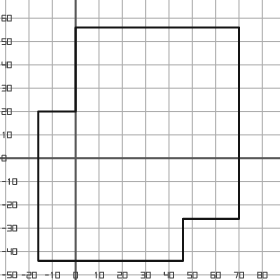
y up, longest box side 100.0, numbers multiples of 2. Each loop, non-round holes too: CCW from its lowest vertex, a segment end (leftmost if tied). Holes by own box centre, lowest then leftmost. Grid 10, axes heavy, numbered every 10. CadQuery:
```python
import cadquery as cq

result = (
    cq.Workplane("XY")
    .moveTo(-16.0, -44.0)
    .lineTo(46.0, -44.0)
    .lineTo(46.0, -26.0)
    .lineTo(70.0, -26.0)
    .lineTo(70.0, 56.0)
    .lineTo(0.0, 56.0)
    .lineTo(0.0, 20.0)
    .lineTo(-16.0, 20.0)
    .close()
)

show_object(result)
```